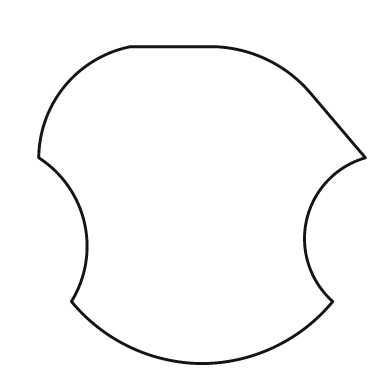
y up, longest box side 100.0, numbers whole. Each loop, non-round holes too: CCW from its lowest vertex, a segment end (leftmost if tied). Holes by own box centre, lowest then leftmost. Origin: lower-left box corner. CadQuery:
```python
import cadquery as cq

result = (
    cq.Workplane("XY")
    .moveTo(50.0, 0.0)
    .threePointArc((72.0, 5.0), (90.0, 19.0))
    .threePointArc((82.0, 44.0), (100.0, 63.0))
    .lineTo(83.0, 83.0)
    .threePointArc((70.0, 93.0), (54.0, 97.0))
    .lineTo(28.0, 97.0)
    .threePointArc((8.0, 85.0), (0.0, 63.0))
    .threePointArc((14.0, 43.0), (10.0, 19.0))
    .threePointArc((28.0, 5.0), (50.0, 0.0))
    .close()
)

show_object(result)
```